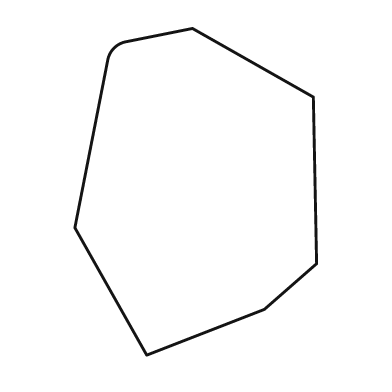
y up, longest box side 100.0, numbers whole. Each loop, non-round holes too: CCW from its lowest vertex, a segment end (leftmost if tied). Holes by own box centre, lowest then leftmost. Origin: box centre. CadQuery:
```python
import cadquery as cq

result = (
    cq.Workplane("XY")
    .moveTo(-15.0, -50.0)
    .lineTo(21.0, -36.0)
    .lineTo(37.0, -22.0)
    .lineTo(36.0, 29.0)
    .lineTo(-1.0, 50.0)
    .lineTo(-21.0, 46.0)
    .threePointArc((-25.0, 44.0), (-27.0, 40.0))
    .lineTo(-37.0, -11.0)
    .close()
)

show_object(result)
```